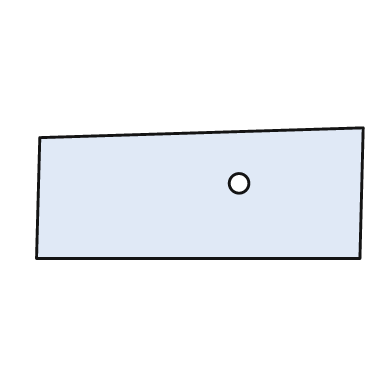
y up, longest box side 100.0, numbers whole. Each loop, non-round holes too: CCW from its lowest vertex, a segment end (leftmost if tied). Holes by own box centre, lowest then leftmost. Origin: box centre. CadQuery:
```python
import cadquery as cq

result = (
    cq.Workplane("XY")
    .moveTo(-50.0, -20.0)
    .lineTo(49.0, -20.0)
    .lineTo(50.0, 20.0)
    .lineTo(-49.0, 17.0)
    .close()
    .moveTo(12.0, 3.0)
    .circle(3.0)
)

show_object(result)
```